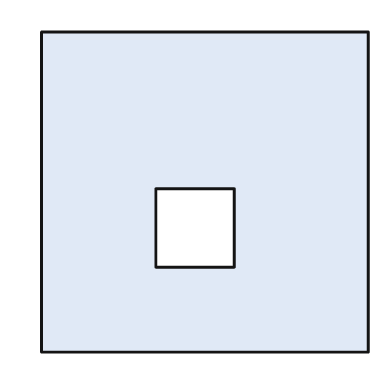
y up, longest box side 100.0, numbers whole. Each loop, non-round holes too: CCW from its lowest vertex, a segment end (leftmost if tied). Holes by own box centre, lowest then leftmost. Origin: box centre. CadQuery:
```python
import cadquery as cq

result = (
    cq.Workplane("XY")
    .moveTo(-50.0, -49.0)
    .lineTo(50.0, -49.0)
    .lineTo(50.0, 49.0)
    .lineTo(-50.0, 49.0)
    .close()
    .moveTo(-15.0, -23.0)
    .lineTo(9.0, -23.0)
    .lineTo(9.0, 1.0)
    .lineTo(-15.0, 1.0)
    .close()
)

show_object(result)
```